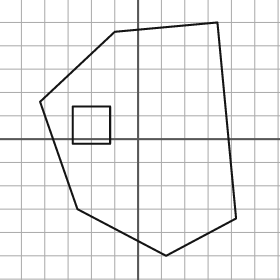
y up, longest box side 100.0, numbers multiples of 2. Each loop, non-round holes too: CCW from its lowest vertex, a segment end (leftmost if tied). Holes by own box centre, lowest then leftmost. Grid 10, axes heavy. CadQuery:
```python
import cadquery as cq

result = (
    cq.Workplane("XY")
    .moveTo(12.0, -50.0)
    .lineTo(42.0, -34.0)
    .lineTo(34.0, 50.0)
    .lineTo(-10.0, 46.0)
    .lineTo(-42.0, 16.0)
    .lineTo(-26.0, -30.0)
    .close()
    .moveTo(-28.0, -2.0)
    .lineTo(-12.0, -2.0)
    .lineTo(-12.0, 14.0)
    .lineTo(-28.0, 14.0)
    .close()
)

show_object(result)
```